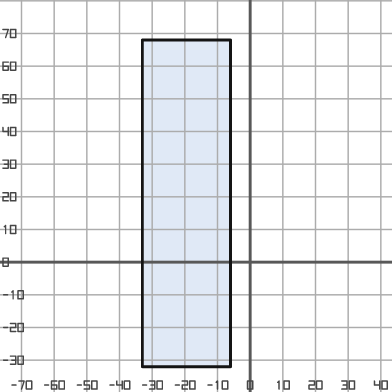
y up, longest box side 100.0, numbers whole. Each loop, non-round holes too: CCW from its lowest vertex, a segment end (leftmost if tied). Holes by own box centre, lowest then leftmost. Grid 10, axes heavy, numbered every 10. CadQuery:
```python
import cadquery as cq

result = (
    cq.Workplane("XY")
    .moveTo(-33.0, -32.0)
    .lineTo(-6.0, -32.0)
    .lineTo(-6.0, 68.0)
    .lineTo(-33.0, 68.0)
    .close()
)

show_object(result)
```